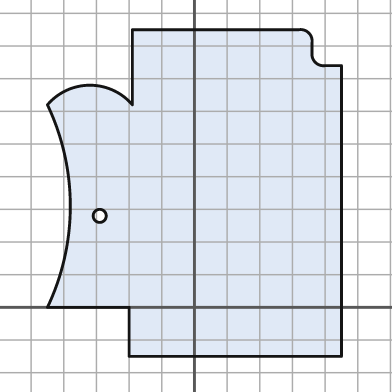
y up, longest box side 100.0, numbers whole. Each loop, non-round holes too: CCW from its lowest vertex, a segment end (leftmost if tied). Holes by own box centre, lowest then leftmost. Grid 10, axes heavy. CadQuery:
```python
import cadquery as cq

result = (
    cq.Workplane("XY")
    .moveTo(-20.0, -15.0)
    .lineTo(45.0, -15.0)
    .lineTo(45.0, 74.0)
    .lineTo(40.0, 74.0)
    .threePointArc((37.0, 75.0), (36.0, 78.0))
    .lineTo(36.0, 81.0)
    .threePointArc((35.0, 84.0), (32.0, 85.0))
    .lineTo(-19.0, 85.0)
    .lineTo(-19.0, 62.0)
    .threePointArc((-32.0, 68.0), (-45.0, 62.0))
    .threePointArc((-38.0, 31.0), (-45.0, 0.0))
    .lineTo(-20.0, 0.0)
    .close()
    .moveTo(-29.0, 28.0)
    .circle(2.0)
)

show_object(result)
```